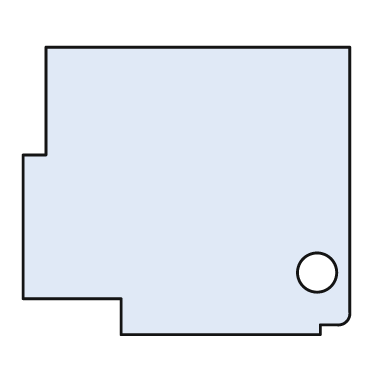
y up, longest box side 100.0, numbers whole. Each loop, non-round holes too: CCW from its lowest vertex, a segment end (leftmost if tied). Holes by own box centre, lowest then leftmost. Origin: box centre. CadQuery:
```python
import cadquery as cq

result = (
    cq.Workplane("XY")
    .moveTo(-20.0, -44.0)
    .lineTo(41.0, -44.0)
    .lineTo(41.0, -41.0)
    .lineTo(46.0, -41.0)
    .threePointArc((49.0, -40.0), (50.0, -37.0))
    .lineTo(50.0, 44.0)
    .lineTo(-43.0, 44.0)
    .lineTo(-43.0, 11.0)
    .lineTo(-50.0, 11.0)
    .lineTo(-50.0, -33.0)
    .lineTo(-20.0, -33.0)
    .close()
    .moveTo(40.0, -25.0)
    .circle(6.0)
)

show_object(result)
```